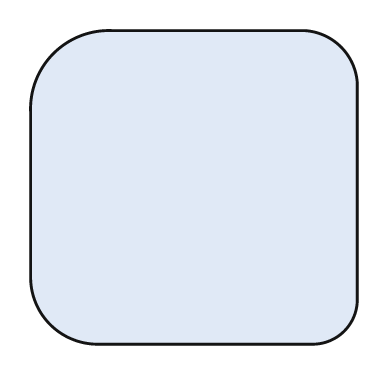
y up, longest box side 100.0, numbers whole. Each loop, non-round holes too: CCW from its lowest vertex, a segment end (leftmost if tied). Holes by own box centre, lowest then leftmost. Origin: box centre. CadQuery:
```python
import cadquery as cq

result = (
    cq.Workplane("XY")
    .moveTo(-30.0, -48.0)
    .lineTo(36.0, -48.0)
    .threePointArc((46.0, -44.0), (50.0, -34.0))
    .lineTo(50.0, 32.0)
    .threePointArc((45.0, 43.0), (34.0, 48.0))
    .lineTo(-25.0, 48.0)
    .threePointArc((-43.0, 41.0), (-50.0, 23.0))
    .lineTo(-50.0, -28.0)
    .threePointArc((-44.0, -42.0), (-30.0, -48.0))
    .close()
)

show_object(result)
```